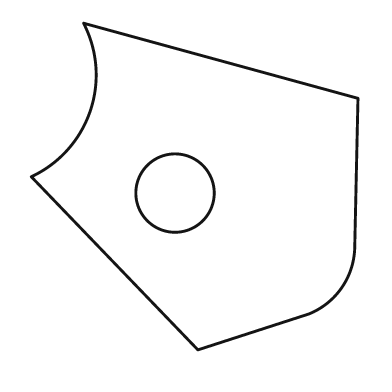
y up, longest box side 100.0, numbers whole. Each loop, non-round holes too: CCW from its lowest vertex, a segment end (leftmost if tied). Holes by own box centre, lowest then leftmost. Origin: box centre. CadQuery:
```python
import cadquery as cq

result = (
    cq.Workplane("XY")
    .moveTo(1.0, -50.0)
    .lineTo(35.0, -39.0)
    .threePointArc((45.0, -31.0), (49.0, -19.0))
    .lineTo(50.0, 27.0)
    .lineTo(-34.0, 50.0)
    .threePointArc((-32.0, 23.0), (-50.0, 3.0))
    .close()
    .moveTo(-6.0, -2.0)
    .circle(12.0)
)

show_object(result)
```